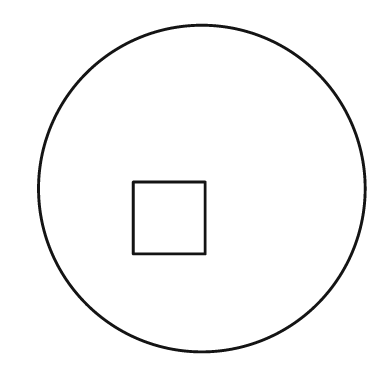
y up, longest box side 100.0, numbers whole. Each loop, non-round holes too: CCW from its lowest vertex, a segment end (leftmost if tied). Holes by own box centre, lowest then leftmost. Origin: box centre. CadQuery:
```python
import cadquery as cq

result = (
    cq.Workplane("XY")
    .moveTo(0.0, 0.0)
    .circle(50.0)
    .moveTo(-21.0, -20.0)
    .lineTo(1.0, -20.0)
    .lineTo(1.0, 2.0)
    .lineTo(-21.0, 2.0)
    .close()
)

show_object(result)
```